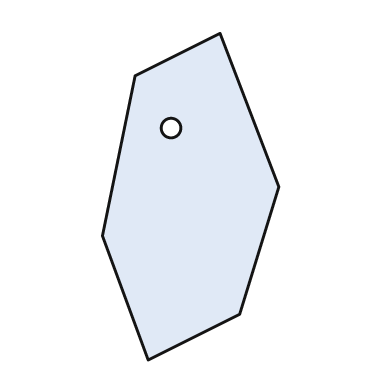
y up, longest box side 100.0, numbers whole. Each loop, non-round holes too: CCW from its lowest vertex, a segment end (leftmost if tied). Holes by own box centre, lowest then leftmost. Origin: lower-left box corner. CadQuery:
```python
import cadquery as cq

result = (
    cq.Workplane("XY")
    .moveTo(14.0, 0.0)
    .lineTo(42.0, 14.0)
    .lineTo(54.0, 53.0)
    .lineTo(36.0, 100.0)
    .lineTo(10.0, 87.0)
    .lineTo(0.0, 38.0)
    .close()
    .moveTo(21.0, 71.0)
    .circle(3.0)
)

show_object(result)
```